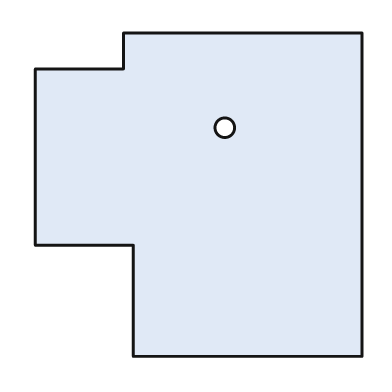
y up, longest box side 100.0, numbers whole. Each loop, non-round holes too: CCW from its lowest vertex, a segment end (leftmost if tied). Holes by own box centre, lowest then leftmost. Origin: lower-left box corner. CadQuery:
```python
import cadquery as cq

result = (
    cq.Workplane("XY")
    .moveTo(30.0, 0.0)
    .lineTo(100.0, 0.0)
    .lineTo(100.0, 99.0)
    .lineTo(27.0, 99.0)
    .lineTo(27.0, 88.0)
    .lineTo(0.0, 88.0)
    .lineTo(0.0, 34.0)
    .lineTo(30.0, 34.0)
    .close()
    .moveTo(58.0, 70.0)
    .circle(3.0)
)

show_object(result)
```